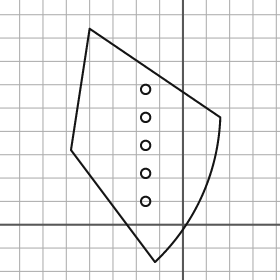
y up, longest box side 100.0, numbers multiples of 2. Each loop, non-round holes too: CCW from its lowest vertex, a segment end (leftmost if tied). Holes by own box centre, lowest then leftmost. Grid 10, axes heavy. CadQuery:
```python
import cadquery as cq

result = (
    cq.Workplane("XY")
    .moveTo(-12.0, -16.0)
    .threePointArc((8.0, 12.0), (16.0, 46.0))
    .lineTo(-40.0, 84.0)
    .lineTo(-48.0, 32.0)
    .close()
    .moveTo(-16.0, 10.0)
    .circle(2.0)
    .moveTo(-16.0, 22.0)
    .circle(2.0)
    .moveTo(-16.0, 34.0)
    .circle(2.0)
    .moveTo(-16.0, 46.0)
    .circle(2.0)
    .moveTo(-16.0, 58.0)
    .circle(2.0)
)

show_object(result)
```